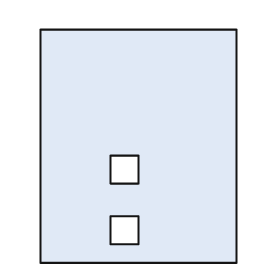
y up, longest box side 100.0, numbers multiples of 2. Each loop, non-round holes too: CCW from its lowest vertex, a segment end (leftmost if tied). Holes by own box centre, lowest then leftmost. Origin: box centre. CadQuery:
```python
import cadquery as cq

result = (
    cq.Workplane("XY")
    .moveTo(-42.0, -50.0)
    .lineTo(42.0, -50.0)
    .lineTo(42.0, 50.0)
    .lineTo(-42.0, 50.0)
    .close()
    .moveTo(-12.0, -42.0)
    .lineTo(0.0, -42.0)
    .lineTo(0.0, -30.0)
    .lineTo(-12.0, -30.0)
    .close()
    .moveTo(-12.0, -16.0)
    .lineTo(0.0, -16.0)
    .lineTo(0.0, -4.0)
    .lineTo(-12.0, -4.0)
    .close()
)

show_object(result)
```